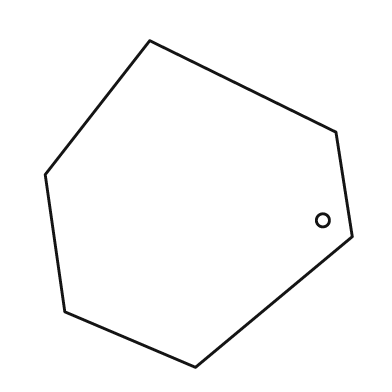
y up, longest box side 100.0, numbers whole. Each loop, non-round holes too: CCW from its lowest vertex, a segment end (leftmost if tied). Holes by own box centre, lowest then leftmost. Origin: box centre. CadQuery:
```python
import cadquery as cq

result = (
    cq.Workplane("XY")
    .moveTo(-1.0, -50.0)
    .lineTo(47.0, -10.0)
    .lineTo(42.0, 22.0)
    .lineTo(-15.0, 50.0)
    .lineTo(-47.0, 9.0)
    .lineTo(-41.0, -33.0)
    .close()
    .moveTo(38.0, -5.0)
    .circle(2.0)
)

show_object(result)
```